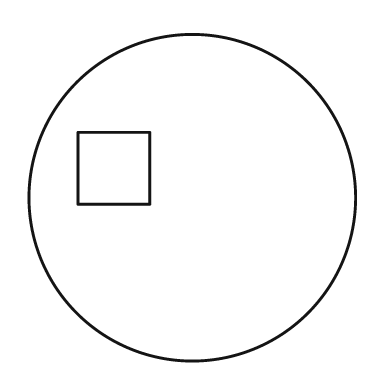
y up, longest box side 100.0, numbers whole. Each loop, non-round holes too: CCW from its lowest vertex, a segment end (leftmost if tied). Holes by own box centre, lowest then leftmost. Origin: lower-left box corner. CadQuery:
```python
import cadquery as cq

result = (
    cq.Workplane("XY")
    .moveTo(50.0, 50.0)
    .circle(50.0)
    .moveTo(15.0, 48.0)
    .lineTo(37.0, 48.0)
    .lineTo(37.0, 70.0)
    .lineTo(15.0, 70.0)
    .close()
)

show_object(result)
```